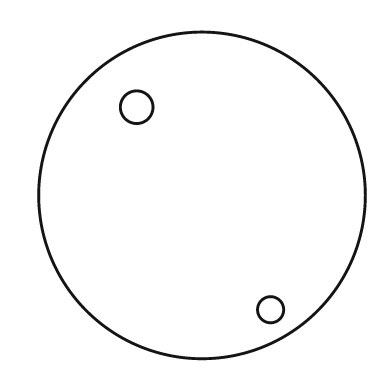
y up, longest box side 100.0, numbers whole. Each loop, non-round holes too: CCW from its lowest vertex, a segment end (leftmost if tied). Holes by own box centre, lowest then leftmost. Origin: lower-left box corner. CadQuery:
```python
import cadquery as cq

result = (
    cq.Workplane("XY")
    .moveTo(50.0, 50.0)
    .circle(50.0)
    .moveTo(71.0, 15.0)
    .circle(4.0)
    .moveTo(30.0, 77.0)
    .circle(5.0)
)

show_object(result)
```